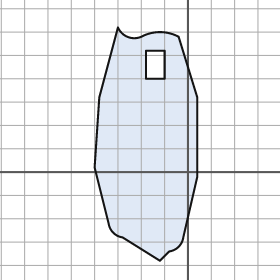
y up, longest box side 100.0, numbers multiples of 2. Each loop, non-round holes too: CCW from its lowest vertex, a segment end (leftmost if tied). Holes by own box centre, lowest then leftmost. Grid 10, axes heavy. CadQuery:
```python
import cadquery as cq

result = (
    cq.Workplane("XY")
    .moveTo(-12.0, -38.0)
    .lineTo(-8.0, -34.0)
    .threePointArc((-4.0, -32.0), (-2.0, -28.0))
    .lineTo(4.0, -2.0)
    .lineTo(4.0, 32.0)
    .lineTo(-4.0, 58.0)
    .threePointArc((-12.0, 60.0), (-20.0, 58.0))
    .threePointArc((-26.0, 58.0), (-30.0, 62.0))
    .lineTo(-38.0, 32.0)
    .lineTo(-40.0, 2.0)
    .lineTo(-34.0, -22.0)
    .threePointArc((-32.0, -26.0), (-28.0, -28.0))
    .close()
    .moveTo(-18.0, 40.0)
    .lineTo(-10.0, 40.0)
    .lineTo(-10.0, 52.0)
    .lineTo(-18.0, 52.0)
    .close()
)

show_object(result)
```